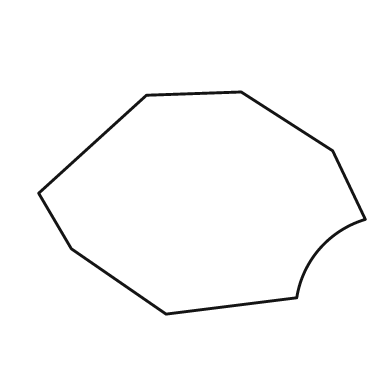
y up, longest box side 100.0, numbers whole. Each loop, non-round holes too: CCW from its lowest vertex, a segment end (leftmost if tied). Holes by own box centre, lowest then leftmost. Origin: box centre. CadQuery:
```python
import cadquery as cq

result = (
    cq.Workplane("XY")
    .moveTo(-11.0, -34.0)
    .lineTo(29.0, -29.0)
    .threePointArc((36.0, -14.0), (50.0, -5.0))
    .lineTo(40.0, 16.0)
    .lineTo(12.0, 34.0)
    .lineTo(-17.0, 33.0)
    .lineTo(-50.0, 3.0)
    .lineTo(-40.0, -14.0)
    .close()
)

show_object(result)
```